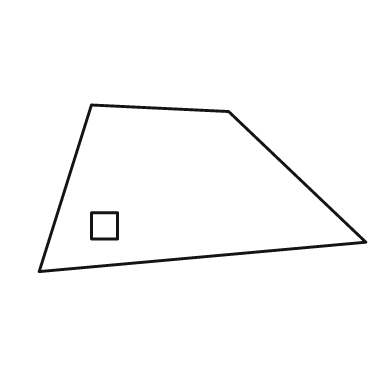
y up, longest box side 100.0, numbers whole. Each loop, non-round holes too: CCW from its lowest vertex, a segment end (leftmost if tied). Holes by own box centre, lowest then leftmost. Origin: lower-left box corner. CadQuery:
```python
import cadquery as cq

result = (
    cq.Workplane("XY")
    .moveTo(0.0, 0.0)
    .lineTo(100.0, 9.0)
    .lineTo(58.0, 49.0)
    .lineTo(16.0, 51.0)
    .close()
    .moveTo(16.0, 10.0)
    .lineTo(24.0, 10.0)
    .lineTo(24.0, 18.0)
    .lineTo(16.0, 18.0)
    .close()
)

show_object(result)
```